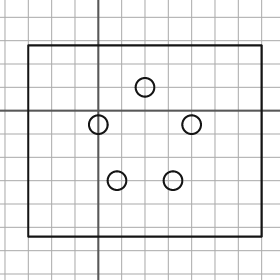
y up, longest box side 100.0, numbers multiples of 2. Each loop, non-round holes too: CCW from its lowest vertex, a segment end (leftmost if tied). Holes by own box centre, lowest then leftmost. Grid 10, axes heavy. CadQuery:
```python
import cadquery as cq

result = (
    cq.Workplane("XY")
    .moveTo(-30.0, -54.0)
    .lineTo(70.0, -54.0)
    .lineTo(70.0, 28.0)
    .lineTo(-30.0, 28.0)
    .close()
    .moveTo(8.0, -30.0)
    .circle(4.0)
    .moveTo(32.0, -30.0)
    .circle(4.0)
    .moveTo(0.0, -6.0)
    .circle(4.0)
    .moveTo(40.0, -6.0)
    .circle(4.0)
    .moveTo(20.0, 10.0)
    .circle(4.0)
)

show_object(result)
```